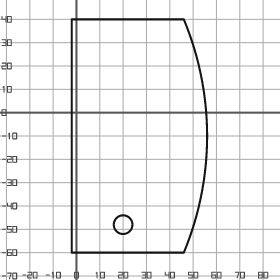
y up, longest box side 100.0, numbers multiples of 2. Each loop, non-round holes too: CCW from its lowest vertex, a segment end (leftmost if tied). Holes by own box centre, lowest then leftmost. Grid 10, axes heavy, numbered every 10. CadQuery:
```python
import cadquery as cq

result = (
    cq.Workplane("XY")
    .moveTo(-2.0, -60.0)
    .lineTo(46.0, -60.0)
    .threePointArc((56.0, -10.0), (46.0, 40.0))
    .lineTo(-2.0, 40.0)
    .close()
    .moveTo(20.0, -48.0)
    .circle(4.0)
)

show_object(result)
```